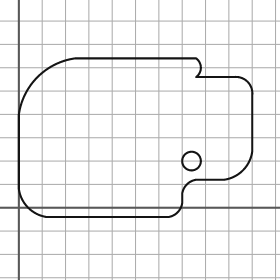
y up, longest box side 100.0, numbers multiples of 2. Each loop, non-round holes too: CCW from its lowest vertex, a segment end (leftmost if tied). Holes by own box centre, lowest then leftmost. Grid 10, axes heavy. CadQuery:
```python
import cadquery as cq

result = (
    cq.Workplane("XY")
    .moveTo(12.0, -4.0)
    .lineTo(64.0, -4.0)
    .threePointArc((68.0, -2.0), (70.0, 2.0))
    .lineTo(70.0, 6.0)
    .threePointArc((72.0, 10.0), (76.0, 12.0))
    .lineTo(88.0, 12.0)
    .threePointArc((96.0, 16.0), (100.0, 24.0))
    .lineTo(100.0, 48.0)
    .threePointArc((98.0, 54.0), (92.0, 56.0))
    .lineTo(76.0, 56.0)
    .threePointArc((78.0, 60.0), (76.0, 64.0))
    .lineTo(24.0, 64.0)
    .threePointArc((8.0, 56.0), (0.0, 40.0))
    .lineTo(0.0, 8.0)
    .threePointArc((4.0, 0.0), (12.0, -4.0))
    .close()
    .moveTo(74.0, 20.0)
    .circle(4.0)
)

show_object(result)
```